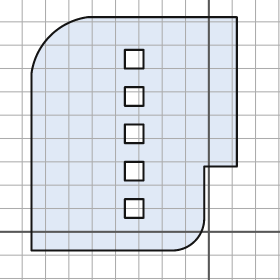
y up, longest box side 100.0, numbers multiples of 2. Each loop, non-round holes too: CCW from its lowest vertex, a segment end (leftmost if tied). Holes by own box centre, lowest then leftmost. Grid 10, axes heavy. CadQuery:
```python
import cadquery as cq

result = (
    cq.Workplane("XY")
    .moveTo(-76.0, -8.0)
    .lineTo(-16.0, -8.0)
    .threePointArc((-6.0, -4.0), (-2.0, 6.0))
    .lineTo(-2.0, 28.0)
    .lineTo(12.0, 28.0)
    .lineTo(12.0, 92.0)
    .lineTo(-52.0, 92.0)
    .threePointArc((-68.0, 84.0), (-76.0, 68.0))
    .close()
    .moveTo(-36.0, 6.0)
    .lineTo(-28.0, 6.0)
    .lineTo(-28.0, 14.0)
    .lineTo(-36.0, 14.0)
    .close()
    .moveTo(-36.0, 22.0)
    .lineTo(-28.0, 22.0)
    .lineTo(-28.0, 30.0)
    .lineTo(-36.0, 30.0)
    .close()
    .moveTo(-36.0, 38.0)
    .lineTo(-28.0, 38.0)
    .lineTo(-28.0, 46.0)
    .lineTo(-36.0, 46.0)
    .close()
    .moveTo(-36.0, 54.0)
    .lineTo(-28.0, 54.0)
    .lineTo(-28.0, 62.0)
    .lineTo(-36.0, 62.0)
    .close()
    .moveTo(-36.0, 70.0)
    .lineTo(-28.0, 70.0)
    .lineTo(-28.0, 78.0)
    .lineTo(-36.0, 78.0)
    .close()
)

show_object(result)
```